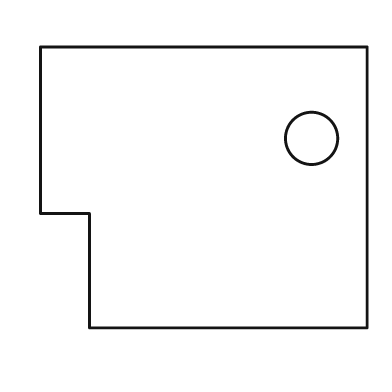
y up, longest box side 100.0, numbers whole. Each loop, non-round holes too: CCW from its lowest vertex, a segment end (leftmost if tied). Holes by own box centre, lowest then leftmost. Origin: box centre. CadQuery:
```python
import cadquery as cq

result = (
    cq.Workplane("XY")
    .moveTo(-35.0, -43.0)
    .lineTo(50.0, -43.0)
    .lineTo(50.0, 43.0)
    .lineTo(-50.0, 43.0)
    .lineTo(-50.0, -8.0)
    .lineTo(-35.0, -8.0)
    .close()
    .moveTo(33.0, 15.0)
    .circle(8.0)
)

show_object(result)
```